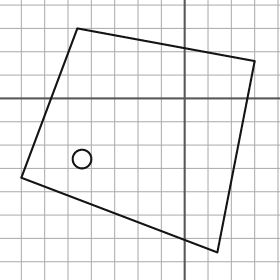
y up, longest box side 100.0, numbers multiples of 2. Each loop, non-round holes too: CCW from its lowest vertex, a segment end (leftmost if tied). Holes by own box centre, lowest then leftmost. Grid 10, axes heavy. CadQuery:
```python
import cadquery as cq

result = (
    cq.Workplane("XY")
    .moveTo(14.0, -66.0)
    .lineTo(30.0, 16.0)
    .lineTo(-46.0, 30.0)
    .lineTo(-70.0, -34.0)
    .close()
    .moveTo(-44.0, -26.0)
    .circle(4.0)
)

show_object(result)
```